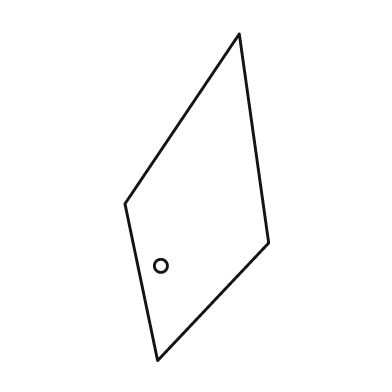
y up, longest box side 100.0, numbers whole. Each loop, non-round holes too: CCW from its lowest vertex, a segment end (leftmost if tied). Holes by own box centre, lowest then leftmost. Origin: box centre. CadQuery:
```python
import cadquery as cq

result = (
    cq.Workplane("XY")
    .moveTo(-12.0, -50.0)
    .lineTo(22.0, -14.0)
    .lineTo(13.0, 50.0)
    .lineTo(-22.0, -2.0)
    .close()
    .moveTo(-11.0, -21.0)
    .circle(2.0)
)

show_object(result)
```